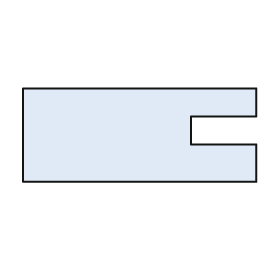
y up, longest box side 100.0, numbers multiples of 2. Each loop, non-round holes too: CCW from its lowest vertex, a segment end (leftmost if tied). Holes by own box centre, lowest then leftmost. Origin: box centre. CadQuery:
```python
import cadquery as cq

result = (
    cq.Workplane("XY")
    .moveTo(-50.0, -20.0)
    .lineTo(50.0, -20.0)
    .lineTo(50.0, -4.0)
    .lineTo(22.0, -4.0)
    .lineTo(22.0, 8.0)
    .lineTo(50.0, 8.0)
    .lineTo(50.0, 20.0)
    .lineTo(-50.0, 20.0)
    .close()
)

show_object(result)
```